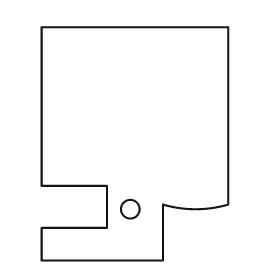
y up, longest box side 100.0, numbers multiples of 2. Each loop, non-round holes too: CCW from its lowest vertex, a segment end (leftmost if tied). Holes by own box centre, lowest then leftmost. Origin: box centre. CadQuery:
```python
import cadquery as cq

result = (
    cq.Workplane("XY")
    .moveTo(-40.0, -50.0)
    .lineTo(12.0, -50.0)
    .lineTo(12.0, -26.0)
    .threePointArc((26.0, -28.0), (40.0, -26.0))
    .lineTo(40.0, 50.0)
    .lineTo(-40.0, 50.0)
    .lineTo(-40.0, -18.0)
    .lineTo(-12.0, -18.0)
    .lineTo(-12.0, -36.0)
    .lineTo(-40.0, -36.0)
    .close()
    .moveTo(-2.0, -28.0)
    .circle(4.0)
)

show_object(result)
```